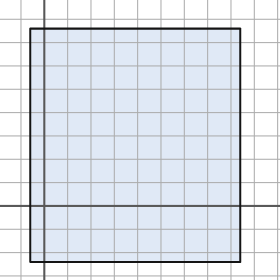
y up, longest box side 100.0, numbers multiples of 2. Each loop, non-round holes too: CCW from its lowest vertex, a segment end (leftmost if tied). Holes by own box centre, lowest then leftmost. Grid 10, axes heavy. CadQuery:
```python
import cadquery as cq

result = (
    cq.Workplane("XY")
    .moveTo(-6.0, -24.0)
    .lineTo(84.0, -24.0)
    .lineTo(84.0, 76.0)
    .lineTo(-6.0, 76.0)
    .close()
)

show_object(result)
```